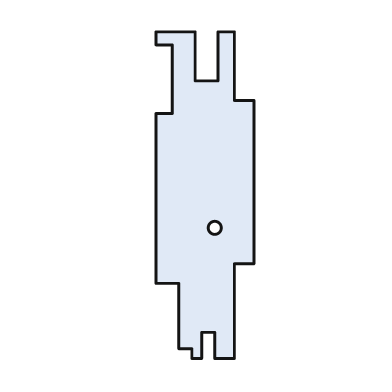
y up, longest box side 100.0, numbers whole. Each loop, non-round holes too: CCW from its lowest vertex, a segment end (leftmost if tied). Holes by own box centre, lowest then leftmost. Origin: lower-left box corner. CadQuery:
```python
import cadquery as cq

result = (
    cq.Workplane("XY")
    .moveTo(11.0, 0.0)
    .lineTo(14.0, 0.0)
    .lineTo(14.0, 8.0)
    .lineTo(18.0, 8.0)
    .lineTo(18.0, 0.0)
    .lineTo(24.0, 0.0)
    .lineTo(24.0, 29.0)
    .lineTo(30.0, 29.0)
    .lineTo(30.0, 79.0)
    .lineTo(24.0, 79.0)
    .lineTo(24.0, 100.0)
    .lineTo(19.0, 100.0)
    .lineTo(19.0, 85.0)
    .lineTo(12.0, 85.0)
    .lineTo(12.0, 100.0)
    .lineTo(0.0, 100.0)
    .lineTo(0.0, 96.0)
    .lineTo(5.0, 96.0)
    .lineTo(5.0, 75.0)
    .lineTo(0.0, 75.0)
    .lineTo(0.0, 23.0)
    .lineTo(7.0, 23.0)
    .lineTo(7.0, 3.0)
    .lineTo(11.0, 3.0)
    .close()
    .moveTo(18.0, 40.0)
    .circle(2.0)
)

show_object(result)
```